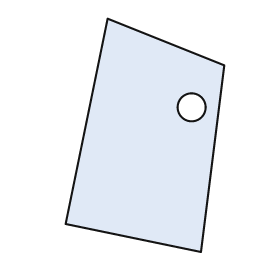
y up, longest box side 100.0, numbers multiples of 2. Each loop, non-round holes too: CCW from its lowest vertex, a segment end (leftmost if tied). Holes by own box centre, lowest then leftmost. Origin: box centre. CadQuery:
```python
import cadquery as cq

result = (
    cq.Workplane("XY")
    .moveTo(24.0, -50.0)
    .lineTo(34.0, 30.0)
    .lineTo(-16.0, 50.0)
    .lineTo(-34.0, -38.0)
    .close()
    .moveTo(20.0, 12.0)
    .circle(6.0)
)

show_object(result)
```